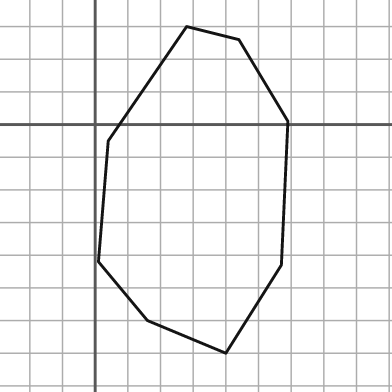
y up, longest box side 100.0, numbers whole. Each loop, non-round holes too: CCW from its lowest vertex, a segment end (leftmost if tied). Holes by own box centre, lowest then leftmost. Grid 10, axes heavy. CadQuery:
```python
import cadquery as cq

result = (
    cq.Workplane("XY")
    .moveTo(40.0, -70.0)
    .lineTo(57.0, -43.0)
    .lineTo(59.0, 1.0)
    .lineTo(44.0, 26.0)
    .lineTo(28.0, 30.0)
    .lineTo(4.0, -5.0)
    .lineTo(1.0, -42.0)
    .lineTo(16.0, -60.0)
    .close()
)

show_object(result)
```